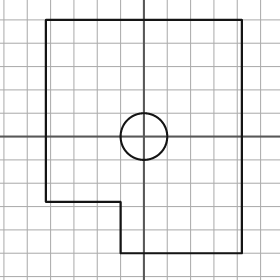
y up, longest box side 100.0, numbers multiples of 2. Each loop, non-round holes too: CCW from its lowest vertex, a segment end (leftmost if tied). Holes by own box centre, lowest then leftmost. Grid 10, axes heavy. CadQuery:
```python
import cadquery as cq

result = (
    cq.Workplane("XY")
    .moveTo(-10.0, -50.0)
    .lineTo(42.0, -50.0)
    .lineTo(42.0, 50.0)
    .lineTo(-42.0, 50.0)
    .lineTo(-42.0, -28.0)
    .lineTo(-10.0, -28.0)
    .close()
    .moveTo(0.0, 0.0)
    .circle(10.0)
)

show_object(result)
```